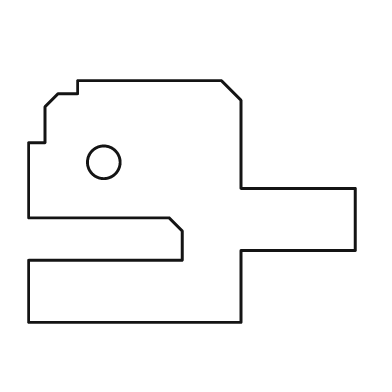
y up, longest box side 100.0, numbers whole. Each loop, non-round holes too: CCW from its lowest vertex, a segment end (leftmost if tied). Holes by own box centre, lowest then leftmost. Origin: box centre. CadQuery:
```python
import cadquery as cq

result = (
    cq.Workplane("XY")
    .moveTo(-50.0, -37.0)
    .lineTo(15.0, -37.0)
    .lineTo(15.0, -15.0)
    .lineTo(50.0, -15.0)
    .lineTo(50.0, 4.0)
    .lineTo(15.0, 4.0)
    .lineTo(15.0, 31.0)
    .lineTo(9.0, 37.0)
    .lineTo(-35.0, 37.0)
    .lineTo(-35.0, 33.0)
    .lineTo(-41.0, 33.0)
    .lineTo(-45.0, 29.0)
    .lineTo(-45.0, 18.0)
    .lineTo(-50.0, 18.0)
    .lineTo(-50.0, -5.0)
    .lineTo(-7.0, -5.0)
    .lineTo(-3.0, -9.0)
    .lineTo(-3.0, -18.0)
    .lineTo(-50.0, -18.0)
    .close()
    .moveTo(-27.0, 12.0)
    .circle(5.0)
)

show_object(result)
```